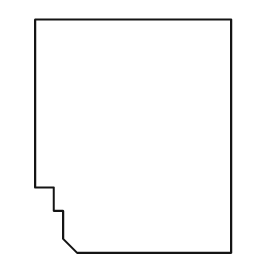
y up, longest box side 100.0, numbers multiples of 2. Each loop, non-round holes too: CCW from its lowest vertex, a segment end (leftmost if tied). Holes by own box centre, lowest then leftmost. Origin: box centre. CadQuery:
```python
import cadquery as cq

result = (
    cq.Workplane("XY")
    .moveTo(-24.0, -50.0)
    .lineTo(42.0, -50.0)
    .lineTo(42.0, 50.0)
    .lineTo(-42.0, 50.0)
    .lineTo(-42.0, -22.0)
    .lineTo(-34.0, -22.0)
    .lineTo(-34.0, -32.0)
    .lineTo(-30.0, -32.0)
    .lineTo(-30.0, -44.0)
    .close()
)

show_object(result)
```